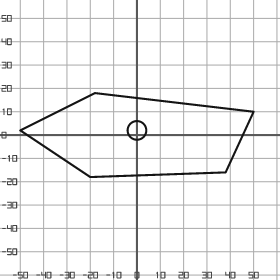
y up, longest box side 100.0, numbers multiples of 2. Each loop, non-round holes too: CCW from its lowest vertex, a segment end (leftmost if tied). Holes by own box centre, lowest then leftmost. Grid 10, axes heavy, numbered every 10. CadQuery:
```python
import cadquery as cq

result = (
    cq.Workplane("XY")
    .moveTo(-20.0, -18.0)
    .lineTo(38.0, -16.0)
    .lineTo(50.0, 10.0)
    .lineTo(-18.0, 18.0)
    .lineTo(-50.0, 2.0)
    .close()
    .moveTo(0.0, 2.0)
    .circle(4.0)
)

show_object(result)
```